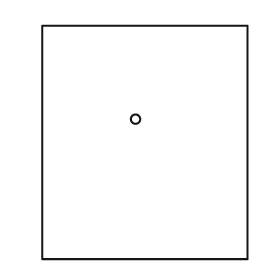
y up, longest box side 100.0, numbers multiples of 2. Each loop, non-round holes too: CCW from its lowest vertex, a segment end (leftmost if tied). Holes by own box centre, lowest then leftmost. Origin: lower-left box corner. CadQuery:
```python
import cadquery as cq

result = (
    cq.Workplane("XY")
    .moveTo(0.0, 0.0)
    .lineTo(88.0, 0.0)
    .lineTo(88.0, 100.0)
    .lineTo(0.0, 100.0)
    .close()
    .moveTo(40.0, 60.0)
    .circle(2.0)
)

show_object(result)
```